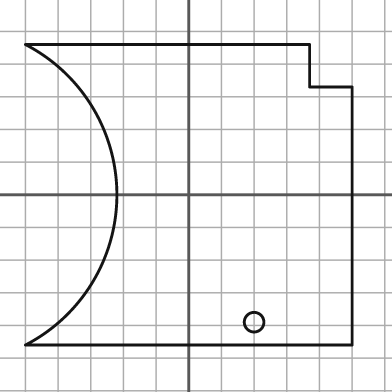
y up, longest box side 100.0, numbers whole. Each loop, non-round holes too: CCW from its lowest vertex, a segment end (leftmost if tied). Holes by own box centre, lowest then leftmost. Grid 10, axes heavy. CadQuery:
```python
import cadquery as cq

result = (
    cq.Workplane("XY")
    .moveTo(-50.0, -46.0)
    .lineTo(50.0, -46.0)
    .lineTo(50.0, 33.0)
    .lineTo(37.0, 33.0)
    .lineTo(37.0, 46.0)
    .lineTo(-50.0, 46.0)
    .threePointArc((-22.0, 0.0), (-50.0, -46.0))
    .close()
    .moveTo(20.0, -39.0)
    .circle(3.0)
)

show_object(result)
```